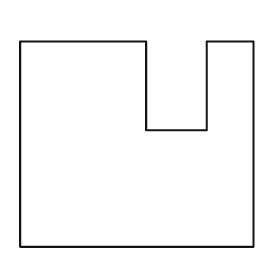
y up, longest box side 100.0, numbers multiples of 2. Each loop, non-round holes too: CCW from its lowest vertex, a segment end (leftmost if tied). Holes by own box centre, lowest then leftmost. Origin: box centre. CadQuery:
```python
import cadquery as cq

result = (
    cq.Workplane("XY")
    .moveTo(-50.0, -44.0)
    .lineTo(50.0, -44.0)
    .lineTo(50.0, 44.0)
    .lineTo(30.0, 44.0)
    .lineTo(30.0, 6.0)
    .lineTo(4.0, 6.0)
    .lineTo(4.0, 44.0)
    .lineTo(-50.0, 44.0)
    .close()
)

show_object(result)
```